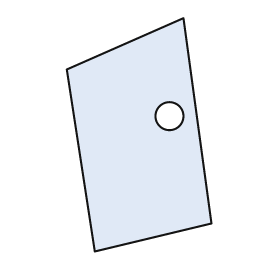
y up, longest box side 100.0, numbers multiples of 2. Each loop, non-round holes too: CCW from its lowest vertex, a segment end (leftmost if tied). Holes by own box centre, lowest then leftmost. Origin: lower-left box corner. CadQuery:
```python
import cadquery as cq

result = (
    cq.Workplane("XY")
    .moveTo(12.0, 0.0)
    .lineTo(62.0, 12.0)
    .lineTo(50.0, 100.0)
    .lineTo(0.0, 78.0)
    .close()
    .moveTo(44.0, 58.0)
    .circle(6.0)
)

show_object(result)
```